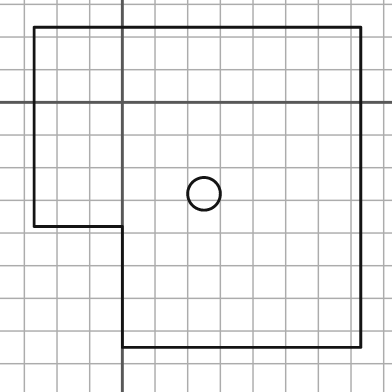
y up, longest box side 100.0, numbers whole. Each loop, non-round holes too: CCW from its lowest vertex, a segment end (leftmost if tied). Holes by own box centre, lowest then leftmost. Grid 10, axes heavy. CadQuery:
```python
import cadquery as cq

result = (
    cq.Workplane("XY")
    .moveTo(0.0, -75.0)
    .lineTo(73.0, -75.0)
    .lineTo(73.0, 23.0)
    .lineTo(-27.0, 23.0)
    .lineTo(-27.0, -38.0)
    .lineTo(0.0, -38.0)
    .close()
    .moveTo(25.0, -28.0)
    .circle(5.0)
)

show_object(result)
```